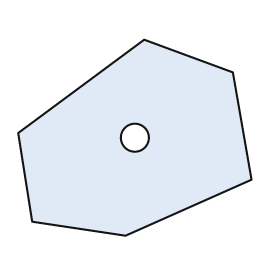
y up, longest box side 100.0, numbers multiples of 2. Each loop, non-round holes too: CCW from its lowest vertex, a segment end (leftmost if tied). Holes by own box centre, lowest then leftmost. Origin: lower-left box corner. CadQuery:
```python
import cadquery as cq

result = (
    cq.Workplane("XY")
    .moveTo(46.0, 0.0)
    .lineTo(100.0, 24.0)
    .lineTo(92.0, 70.0)
    .lineTo(54.0, 84.0)
    .lineTo(0.0, 44.0)
    .lineTo(6.0, 6.0)
    .close()
    .moveTo(50.0, 42.0)
    .circle(6.0)
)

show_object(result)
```